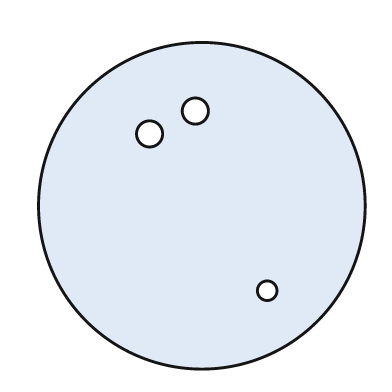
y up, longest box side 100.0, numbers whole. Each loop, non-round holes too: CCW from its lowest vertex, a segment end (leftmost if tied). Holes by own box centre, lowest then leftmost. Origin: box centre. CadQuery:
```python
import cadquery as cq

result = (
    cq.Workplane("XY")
    .moveTo(0.0, 0.0)
    .circle(50.0)
    .moveTo(20.0, -26.0)
    .circle(3.0)
    .moveTo(-16.0, 22.0)
    .circle(4.0)
    .moveTo(-2.0, 29.0)
    .circle(4.0)
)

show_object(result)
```